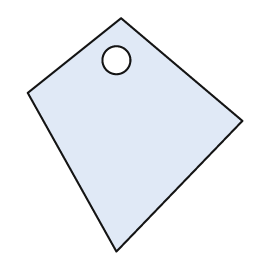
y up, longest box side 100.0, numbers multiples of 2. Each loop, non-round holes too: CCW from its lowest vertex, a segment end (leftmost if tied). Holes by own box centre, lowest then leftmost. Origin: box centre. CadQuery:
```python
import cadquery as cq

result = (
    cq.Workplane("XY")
    .moveTo(-8.0, -50.0)
    .lineTo(46.0, 6.0)
    .lineTo(-6.0, 50.0)
    .lineTo(-46.0, 18.0)
    .close()
    .moveTo(-8.0, 32.0)
    .circle(6.0)
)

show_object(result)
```